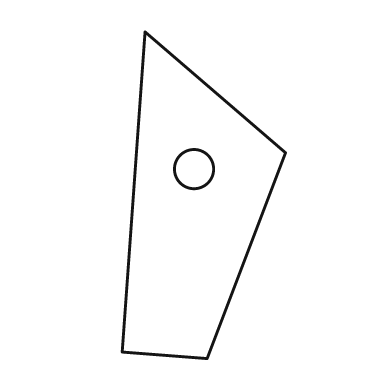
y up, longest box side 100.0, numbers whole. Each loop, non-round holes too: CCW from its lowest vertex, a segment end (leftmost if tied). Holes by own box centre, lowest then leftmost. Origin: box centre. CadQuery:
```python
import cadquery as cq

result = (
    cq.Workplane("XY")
    .moveTo(1.0, -50.0)
    .lineTo(25.0, 13.0)
    .lineTo(-18.0, 50.0)
    .lineTo(-25.0, -48.0)
    .close()
    .moveTo(-3.0, 8.0)
    .circle(6.0)
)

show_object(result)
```